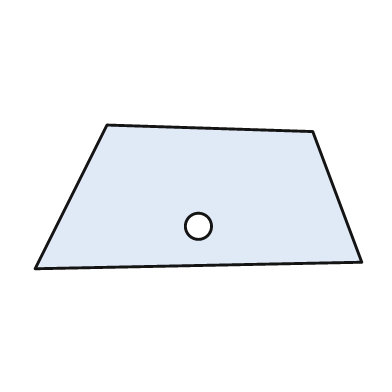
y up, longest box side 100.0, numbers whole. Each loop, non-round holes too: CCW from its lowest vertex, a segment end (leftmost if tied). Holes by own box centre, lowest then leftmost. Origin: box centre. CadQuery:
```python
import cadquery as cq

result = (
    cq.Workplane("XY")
    .moveTo(-50.0, -22.0)
    .lineTo(50.0, -20.0)
    .lineTo(35.0, 20.0)
    .lineTo(-28.0, 22.0)
    .close()
    .moveTo(0.0, -9.0)
    .circle(4.0)
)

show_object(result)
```